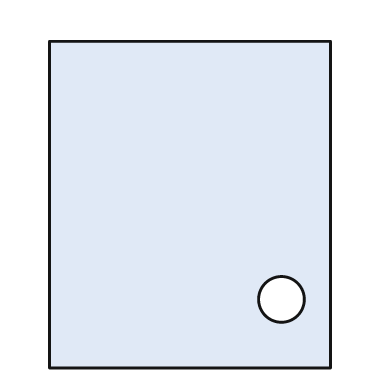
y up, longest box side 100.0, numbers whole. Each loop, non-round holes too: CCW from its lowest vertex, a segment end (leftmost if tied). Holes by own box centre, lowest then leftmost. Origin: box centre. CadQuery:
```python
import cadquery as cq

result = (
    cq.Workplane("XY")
    .moveTo(-43.0, -50.0)
    .lineTo(43.0, -50.0)
    .lineTo(43.0, 50.0)
    .lineTo(-43.0, 50.0)
    .close()
    .moveTo(28.0, -29.0)
    .circle(7.0)
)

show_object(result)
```